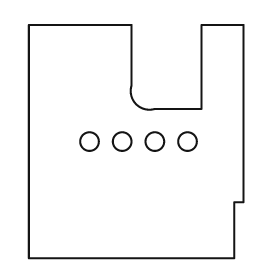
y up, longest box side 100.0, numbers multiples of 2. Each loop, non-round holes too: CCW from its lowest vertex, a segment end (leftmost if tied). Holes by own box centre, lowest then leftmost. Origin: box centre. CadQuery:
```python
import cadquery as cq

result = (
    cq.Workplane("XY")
    .moveTo(-46.0, -50.0)
    .lineTo(42.0, -50.0)
    .lineTo(42.0, -26.0)
    .lineTo(46.0, -26.0)
    .lineTo(46.0, 50.0)
    .lineTo(28.0, 50.0)
    .lineTo(28.0, 14.0)
    .lineTo(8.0, 14.0)
    .threePointArc((0.0, 16.0), (-2.0, 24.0))
    .lineTo(-2.0, 50.0)
    .lineTo(-46.0, 50.0)
    .close()
    .moveTo(-20.0, 0.0)
    .circle(4.0)
    .moveTo(-6.0, 0.0)
    .circle(4.0)
    .moveTo(8.0, 0.0)
    .circle(4.0)
    .moveTo(22.0, 0.0)
    .circle(4.0)
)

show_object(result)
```